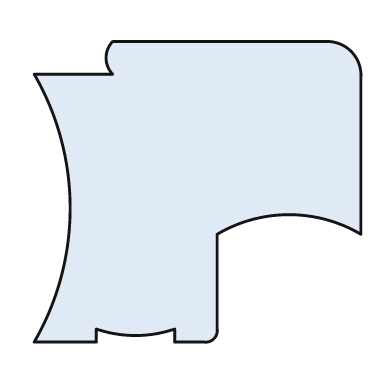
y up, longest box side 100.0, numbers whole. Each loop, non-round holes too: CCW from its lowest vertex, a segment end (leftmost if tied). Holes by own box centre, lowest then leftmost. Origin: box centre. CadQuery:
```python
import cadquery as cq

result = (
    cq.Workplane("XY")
    .moveTo(-50.0, -46.0)
    .lineTo(-31.0, -46.0)
    .lineTo(-31.0, -42.0)
    .threePointArc((-19.0, -44.0), (-7.0, -42.0))
    .lineTo(-7.0, -46.0)
    .lineTo(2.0, -46.0)
    .threePointArc((5.0, -45.0), (6.0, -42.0))
    .lineTo(6.0, -13.0)
    .threePointArc((28.0, -7.0), (50.0, -13.0))
    .lineTo(50.0, 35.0)
    .threePointArc((47.0, 43.0), (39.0, 46.0))
    .lineTo(-26.0, 46.0)
    .threePointArc((-28.0, 41.0), (-26.0, 36.0))
    .lineTo(-50.0, 36.0)
    .threePointArc((-39.0, -5.0), (-50.0, -46.0))
    .close()
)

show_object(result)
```